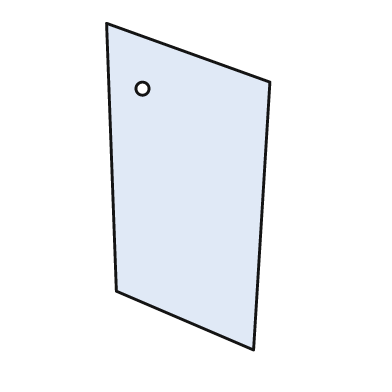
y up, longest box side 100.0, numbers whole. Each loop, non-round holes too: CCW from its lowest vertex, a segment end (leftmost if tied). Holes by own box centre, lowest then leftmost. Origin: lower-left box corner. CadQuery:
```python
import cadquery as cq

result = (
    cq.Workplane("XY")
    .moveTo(45.0, 0.0)
    .lineTo(50.0, 82.0)
    .lineTo(0.0, 100.0)
    .lineTo(3.0, 18.0)
    .close()
    .moveTo(11.0, 80.0)
    .circle(2.0)
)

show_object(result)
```